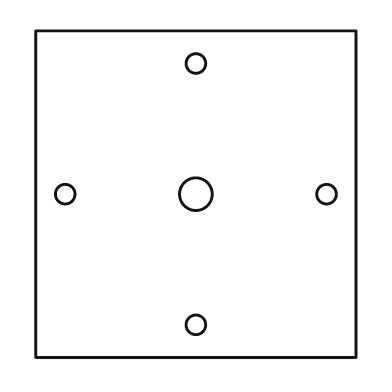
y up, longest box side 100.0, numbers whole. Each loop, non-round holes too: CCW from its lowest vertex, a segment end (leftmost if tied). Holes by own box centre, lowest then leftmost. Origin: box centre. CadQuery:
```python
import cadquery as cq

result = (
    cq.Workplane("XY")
    .moveTo(-49.0, -50.0)
    .lineTo(49.0, -50.0)
    .lineTo(49.0, 50.0)
    .lineTo(-49.0, 50.0)
    .close()
    .moveTo(0.0, -40.0)
    .circle(3.0)
    .moveTo(-40.0, 0.0)
    .circle(3.0)
    .moveTo(0.0, 0.0)
    .circle(5.0)
    .moveTo(40.0, 0.0)
    .circle(3.0)
    .moveTo(0.0, 40.0)
    .circle(3.0)
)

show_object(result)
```